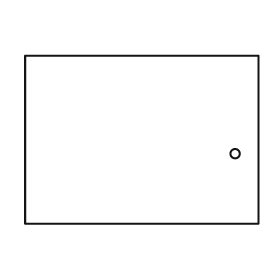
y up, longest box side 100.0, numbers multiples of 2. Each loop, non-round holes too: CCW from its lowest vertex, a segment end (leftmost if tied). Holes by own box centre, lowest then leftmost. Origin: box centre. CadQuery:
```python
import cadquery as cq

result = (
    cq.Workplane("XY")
    .moveTo(-50.0, -36.0)
    .lineTo(50.0, -36.0)
    .lineTo(50.0, 36.0)
    .lineTo(-50.0, 36.0)
    .close()
    .moveTo(40.0, -6.0)
    .circle(2.0)
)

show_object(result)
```